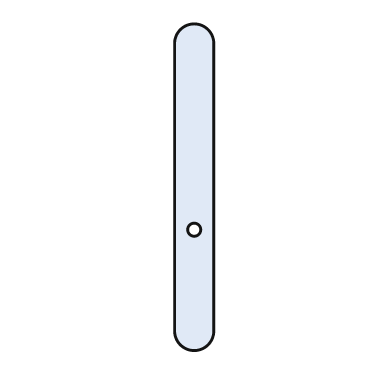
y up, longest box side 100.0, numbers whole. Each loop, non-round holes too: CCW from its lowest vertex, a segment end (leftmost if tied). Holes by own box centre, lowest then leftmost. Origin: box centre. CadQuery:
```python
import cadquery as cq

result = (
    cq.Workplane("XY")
    .moveTo(-6.0, -44.0)
    .threePointArc((0.0, -50.0), (6.0, -44.0))
    .lineTo(6.0, 44.0)
    .threePointArc((0.0, 50.0), (-6.0, 44.0))
    .close()
    .moveTo(0.0, -13.0)
    .circle(2.0)
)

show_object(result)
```